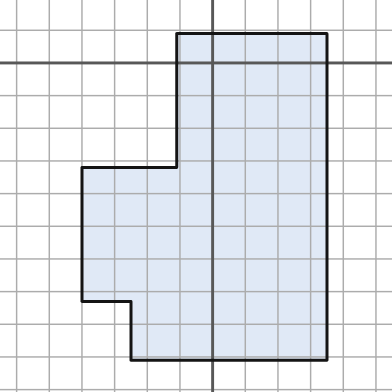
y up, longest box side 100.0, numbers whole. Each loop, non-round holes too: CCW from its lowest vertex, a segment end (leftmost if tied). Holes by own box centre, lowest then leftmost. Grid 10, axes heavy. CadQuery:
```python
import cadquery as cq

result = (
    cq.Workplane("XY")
    .moveTo(-25.0, -91.0)
    .lineTo(35.0, -91.0)
    .lineTo(35.0, 9.0)
    .lineTo(-11.0, 9.0)
    .lineTo(-11.0, -32.0)
    .lineTo(-40.0, -32.0)
    .lineTo(-40.0, -73.0)
    .lineTo(-25.0, -73.0)
    .close()
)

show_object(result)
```